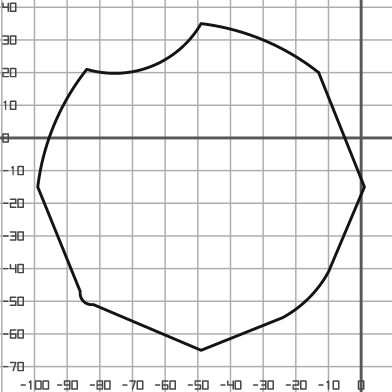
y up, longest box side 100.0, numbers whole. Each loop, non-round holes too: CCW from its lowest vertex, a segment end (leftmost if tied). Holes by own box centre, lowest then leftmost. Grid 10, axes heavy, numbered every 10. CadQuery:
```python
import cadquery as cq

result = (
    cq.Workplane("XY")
    .moveTo(-49.0, -65.0)
    .lineTo(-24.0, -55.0)
    .threePointArc((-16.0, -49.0), (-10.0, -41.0))
    .lineTo(1.0, -15.0)
    .lineTo(-13.0, 20.0)
    .threePointArc((-30.0, 30.0), (-49.0, 35.0))
    .threePointArc((-64.0, 22.0), (-84.0, 21.0))
    .threePointArc((-94.0, 4.0), (-99.0, -15.0))
    .lineTo(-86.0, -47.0)
    .threePointArc((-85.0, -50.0), (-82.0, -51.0))
    .close()
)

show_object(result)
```